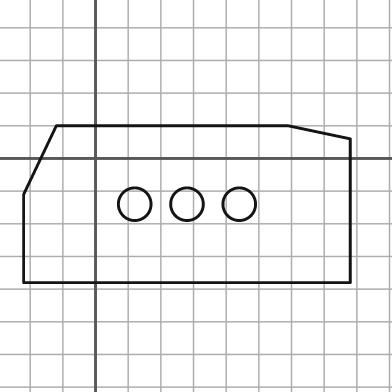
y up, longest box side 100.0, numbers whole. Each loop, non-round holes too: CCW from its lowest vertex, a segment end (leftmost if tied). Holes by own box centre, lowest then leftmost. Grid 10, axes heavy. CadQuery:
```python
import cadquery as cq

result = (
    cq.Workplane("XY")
    .moveTo(-22.0, -38.0)
    .lineTo(78.0, -38.0)
    .lineTo(78.0, 6.0)
    .lineTo(59.0, 10.0)
    .lineTo(-12.0, 10.0)
    .lineTo(-22.0, -11.0)
    .close()
    .moveTo(12.0, -14.0)
    .circle(5.0)
    .moveTo(28.0, -14.0)
    .circle(5.0)
    .moveTo(44.0, -14.0)
    .circle(5.0)
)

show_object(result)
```